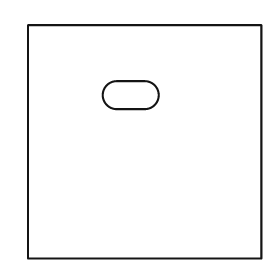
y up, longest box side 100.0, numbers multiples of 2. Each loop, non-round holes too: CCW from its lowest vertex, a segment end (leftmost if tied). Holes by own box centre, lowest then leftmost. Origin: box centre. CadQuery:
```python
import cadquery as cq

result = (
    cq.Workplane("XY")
    .moveTo(-50.0, -50.0)
    .lineTo(50.0, -50.0)
    .lineTo(50.0, 50.0)
    .lineTo(-50.0, 50.0)
    .close()
    .moveTo(-12.0, 14.0)
    .lineTo(0.0, 14.0)
    .threePointArc((6.0, 20.0), (0.0, 26.0))
    .lineTo(-12.0, 26.0)
    .threePointArc((-18.0, 20.0), (-12.0, 14.0))
    .close()
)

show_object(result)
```